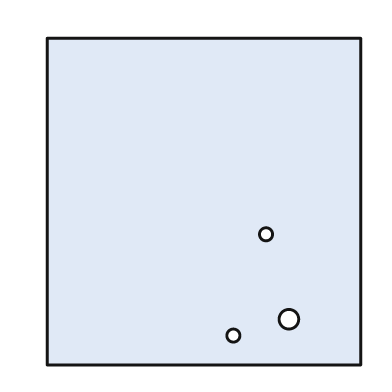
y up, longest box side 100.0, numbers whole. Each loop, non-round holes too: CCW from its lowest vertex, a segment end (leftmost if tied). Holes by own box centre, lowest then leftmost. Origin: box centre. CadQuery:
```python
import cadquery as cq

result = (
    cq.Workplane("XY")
    .moveTo(-48.0, -50.0)
    .lineTo(48.0, -50.0)
    .lineTo(48.0, 50.0)
    .lineTo(-48.0, 50.0)
    .close()
    .moveTo(9.0, -41.0)
    .circle(2.0)
    .moveTo(26.0, -36.0)
    .circle(3.0)
    .moveTo(19.0, -10.0)
    .circle(2.0)
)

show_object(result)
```